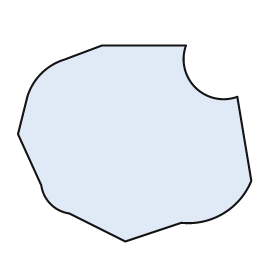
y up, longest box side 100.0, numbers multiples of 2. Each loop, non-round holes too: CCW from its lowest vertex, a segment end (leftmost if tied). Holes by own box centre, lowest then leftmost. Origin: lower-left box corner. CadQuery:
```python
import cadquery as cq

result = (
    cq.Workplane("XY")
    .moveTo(46.0, 0.0)
    .lineTo(70.0, 8.0)
    .threePointArc((88.0, 12.0), (100.0, 26.0))
    .lineTo(94.0, 62.0)
    .threePointArc((76.0, 66.0), (72.0, 84.0))
    .lineTo(36.0, 84.0)
    .lineTo(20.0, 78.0)
    .threePointArc((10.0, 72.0), (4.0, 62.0))
    .lineTo(0.0, 46.0)
    .lineTo(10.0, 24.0)
    .threePointArc((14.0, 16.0), (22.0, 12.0))
    .close()
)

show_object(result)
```